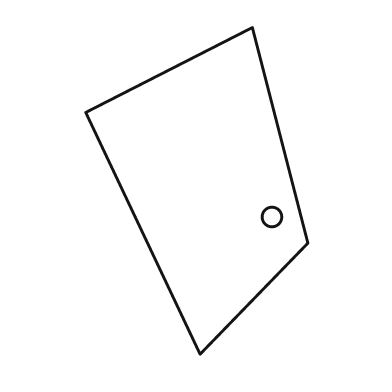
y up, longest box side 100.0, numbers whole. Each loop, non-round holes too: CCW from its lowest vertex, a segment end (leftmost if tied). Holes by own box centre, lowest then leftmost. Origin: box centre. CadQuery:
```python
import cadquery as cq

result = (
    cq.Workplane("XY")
    .moveTo(1.0, -50.0)
    .lineTo(34.0, -16.0)
    .lineTo(17.0, 50.0)
    .lineTo(-34.0, 24.0)
    .close()
    .moveTo(23.0, -8.0)
    .circle(3.0)
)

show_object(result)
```